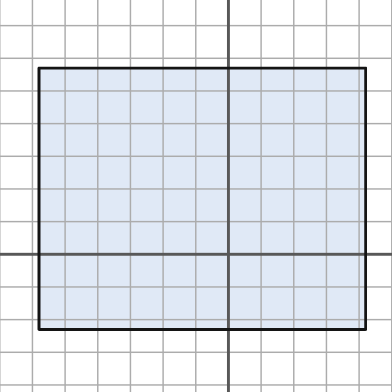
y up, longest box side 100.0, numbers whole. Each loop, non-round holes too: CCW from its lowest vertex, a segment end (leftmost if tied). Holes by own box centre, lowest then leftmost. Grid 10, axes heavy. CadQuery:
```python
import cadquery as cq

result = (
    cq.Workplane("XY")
    .moveTo(-58.0, -23.0)
    .lineTo(42.0, -23.0)
    .lineTo(42.0, 57.0)
    .lineTo(-58.0, 57.0)
    .close()
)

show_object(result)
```